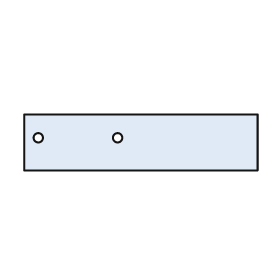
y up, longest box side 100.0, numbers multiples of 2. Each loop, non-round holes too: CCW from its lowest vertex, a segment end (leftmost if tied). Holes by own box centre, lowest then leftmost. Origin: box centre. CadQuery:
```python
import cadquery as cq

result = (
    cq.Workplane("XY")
    .moveTo(-50.0, -12.0)
    .lineTo(50.0, -12.0)
    .lineTo(50.0, 12.0)
    .lineTo(-50.0, 12.0)
    .close()
    .moveTo(-44.0, 2.0)
    .circle(2.0)
    .moveTo(-10.0, 2.0)
    .circle(2.0)
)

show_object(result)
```